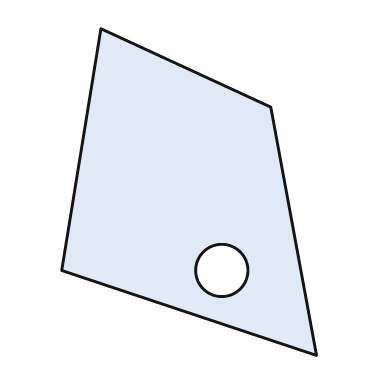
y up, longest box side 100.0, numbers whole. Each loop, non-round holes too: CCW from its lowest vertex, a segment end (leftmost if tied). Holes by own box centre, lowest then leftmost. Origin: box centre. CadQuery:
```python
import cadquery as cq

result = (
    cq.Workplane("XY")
    .moveTo(39.0, -50.0)
    .lineTo(25.0, 26.0)
    .lineTo(-27.0, 50.0)
    .lineTo(-39.0, -24.0)
    .close()
    .moveTo(10.0, -24.0)
    .circle(8.0)
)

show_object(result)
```